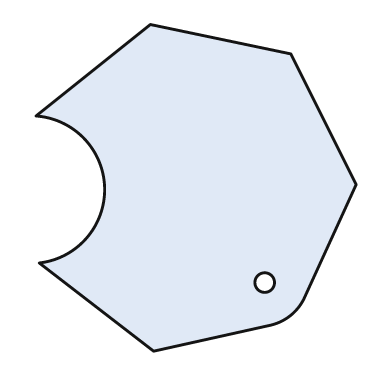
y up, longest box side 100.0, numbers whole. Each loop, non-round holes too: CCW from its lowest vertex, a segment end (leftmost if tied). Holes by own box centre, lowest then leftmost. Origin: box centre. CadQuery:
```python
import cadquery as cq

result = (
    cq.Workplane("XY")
    .moveTo(-13.0, -50.0)
    .lineTo(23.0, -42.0)
    .threePointArc((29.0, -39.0), (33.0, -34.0))
    .lineTo(49.0, 1.0)
    .lineTo(29.0, 41.0)
    .lineTo(-14.0, 50.0)
    .lineTo(-49.0, 22.0)
    .threePointArc((-28.0, 0.0), (-48.0, -23.0))
    .close()
    .moveTo(21.0, -29.0)
    .circle(3.0)
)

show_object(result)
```